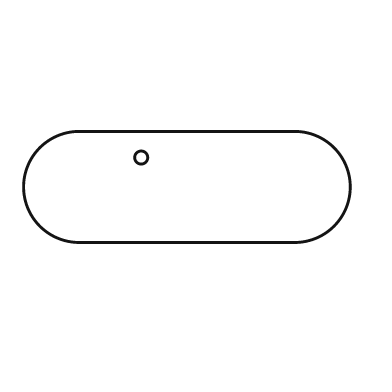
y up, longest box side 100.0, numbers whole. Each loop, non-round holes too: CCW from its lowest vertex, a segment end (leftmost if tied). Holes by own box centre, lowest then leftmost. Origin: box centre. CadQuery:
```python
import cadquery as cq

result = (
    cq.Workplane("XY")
    .moveTo(-33.0, -17.0)
    .lineTo(33.0, -17.0)
    .threePointArc((50.0, 0.0), (33.0, 17.0))
    .lineTo(-33.0, 17.0)
    .threePointArc((-50.0, 0.0), (-33.0, -17.0))
    .close()
    .moveTo(-14.0, 9.0)
    .circle(2.0)
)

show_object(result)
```